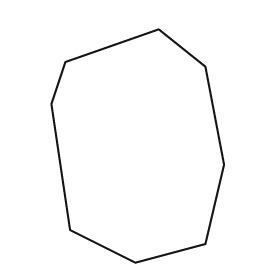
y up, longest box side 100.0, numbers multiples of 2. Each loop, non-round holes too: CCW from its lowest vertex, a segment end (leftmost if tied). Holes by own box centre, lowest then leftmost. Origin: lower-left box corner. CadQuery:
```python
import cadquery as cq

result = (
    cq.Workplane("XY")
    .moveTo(36.0, 0.0)
    .lineTo(66.0, 8.0)
    .lineTo(74.0, 42.0)
    .lineTo(66.0, 84.0)
    .lineTo(46.0, 100.0)
    .lineTo(6.0, 86.0)
    .lineTo(0.0, 68.0)
    .lineTo(8.0, 14.0)
    .close()
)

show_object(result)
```